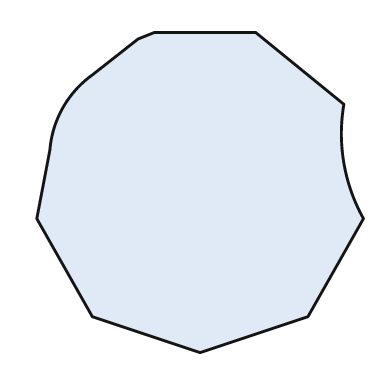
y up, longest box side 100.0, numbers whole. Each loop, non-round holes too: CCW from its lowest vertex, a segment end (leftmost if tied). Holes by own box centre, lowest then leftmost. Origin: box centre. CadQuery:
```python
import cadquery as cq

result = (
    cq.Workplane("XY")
    .moveTo(0.0, -49.0)
    .lineTo(33.0, -38.0)
    .lineTo(50.0, -8.0)
    .threePointArc((44.0, 9.0), (44.0, 27.0))
    .lineTo(17.0, 49.0)
    .lineTo(-14.0, 49.0)
    .lineTo(-19.0, 47.0)
    .lineTo(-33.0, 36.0)
    .threePointArc((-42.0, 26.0), (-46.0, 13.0))
    .lineTo(-50.0, -8.0)
    .lineTo(-33.0, -38.0)
    .close()
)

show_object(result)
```